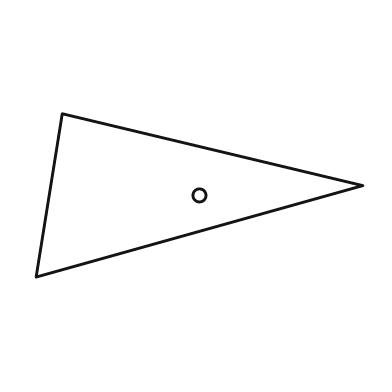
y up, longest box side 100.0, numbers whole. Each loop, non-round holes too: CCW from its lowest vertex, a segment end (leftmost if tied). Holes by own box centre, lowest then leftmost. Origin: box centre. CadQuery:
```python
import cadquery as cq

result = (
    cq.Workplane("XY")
    .moveTo(-50.0, -25.0)
    .lineTo(50.0, 3.0)
    .lineTo(-42.0, 25.0)
    .close()
    .moveTo(0.0, 0.0)
    .circle(2.0)
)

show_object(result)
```